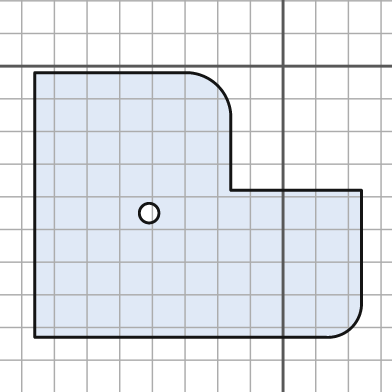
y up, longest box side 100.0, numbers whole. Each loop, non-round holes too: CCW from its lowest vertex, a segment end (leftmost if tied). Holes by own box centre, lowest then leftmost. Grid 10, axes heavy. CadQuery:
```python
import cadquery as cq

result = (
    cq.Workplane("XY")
    .moveTo(-76.0, -83.0)
    .lineTo(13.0, -83.0)
    .threePointArc((21.0, -80.0), (24.0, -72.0))
    .lineTo(24.0, -38.0)
    .lineTo(-16.0, -38.0)
    .lineTo(-16.0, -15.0)
    .threePointArc((-20.0, -6.0), (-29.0, -2.0))
    .lineTo(-76.0, -2.0)
    .close()
    .moveTo(-41.0, -45.0)
    .circle(3.0)
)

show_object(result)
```